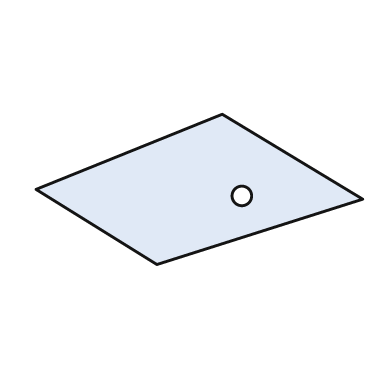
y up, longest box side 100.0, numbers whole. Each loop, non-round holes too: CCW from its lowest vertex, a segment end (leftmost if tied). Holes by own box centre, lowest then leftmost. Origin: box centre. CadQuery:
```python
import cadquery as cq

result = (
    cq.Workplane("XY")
    .moveTo(-13.0, -23.0)
    .lineTo(50.0, -3.0)
    .lineTo(7.0, 23.0)
    .lineTo(-50.0, 0.0)
    .close()
    .moveTo(13.0, -2.0)
    .circle(3.0)
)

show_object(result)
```